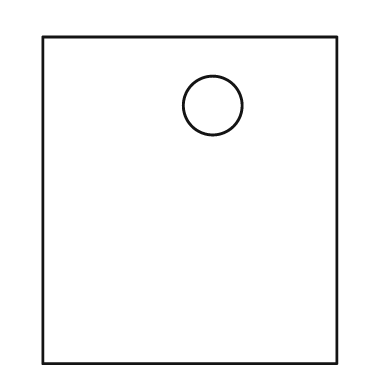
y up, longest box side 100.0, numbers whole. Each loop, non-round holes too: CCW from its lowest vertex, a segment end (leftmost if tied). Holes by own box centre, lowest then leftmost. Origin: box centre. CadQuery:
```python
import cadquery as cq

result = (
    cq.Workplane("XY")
    .moveTo(-45.0, -50.0)
    .lineTo(45.0, -50.0)
    .lineTo(45.0, 50.0)
    .lineTo(-45.0, 50.0)
    .close()
    .moveTo(7.0, 29.0)
    .circle(9.0)
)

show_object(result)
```